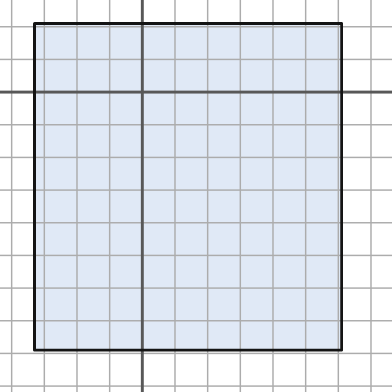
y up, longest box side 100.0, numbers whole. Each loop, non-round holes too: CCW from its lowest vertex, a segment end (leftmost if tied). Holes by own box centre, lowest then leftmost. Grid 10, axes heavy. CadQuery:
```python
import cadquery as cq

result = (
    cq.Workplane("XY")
    .moveTo(-33.0, -79.0)
    .lineTo(61.0, -79.0)
    .lineTo(61.0, 21.0)
    .lineTo(-33.0, 21.0)
    .close()
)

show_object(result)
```